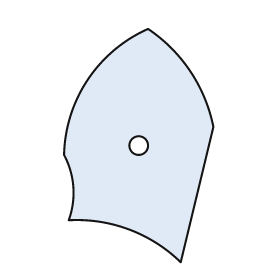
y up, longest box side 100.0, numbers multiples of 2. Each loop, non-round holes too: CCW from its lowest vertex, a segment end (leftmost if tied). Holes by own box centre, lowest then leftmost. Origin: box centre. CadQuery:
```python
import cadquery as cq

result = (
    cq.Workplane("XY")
    .moveTo(18.0, -50.0)
    .lineTo(32.0, 8.0)
    .threePointArc((22.0, 32.0), (4.0, 50.0))
    .threePointArc((-22.0, 28.0), (-32.0, -4.0))
    .threePointArc((-28.0, -18.0), (-30.0, -32.0))
    .threePointArc((-4.0, -36.0), (18.0, -50.0))
    .close()
    .moveTo(0.0, 0.0)
    .circle(4.0)
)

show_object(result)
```